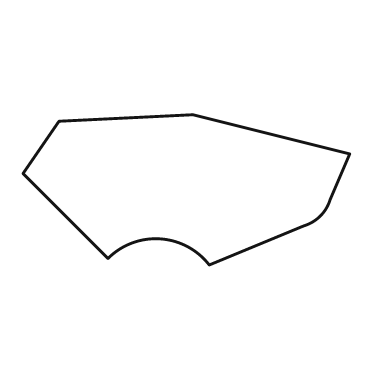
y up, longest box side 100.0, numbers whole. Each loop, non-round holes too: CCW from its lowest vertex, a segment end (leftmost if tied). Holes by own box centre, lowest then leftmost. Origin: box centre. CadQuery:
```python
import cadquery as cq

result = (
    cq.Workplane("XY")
    .moveTo(7.0, -23.0)
    .lineTo(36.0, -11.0)
    .threePointArc((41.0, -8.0), (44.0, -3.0))
    .lineTo(50.0, 11.0)
    .lineTo(2.0, 23.0)
    .lineTo(-39.0, 21.0)
    .lineTo(-50.0, 5.0)
    .lineTo(-24.0, -21.0)
    .threePointArc((-8.0, -15.0), (7.0, -23.0))
    .close()
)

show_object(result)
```